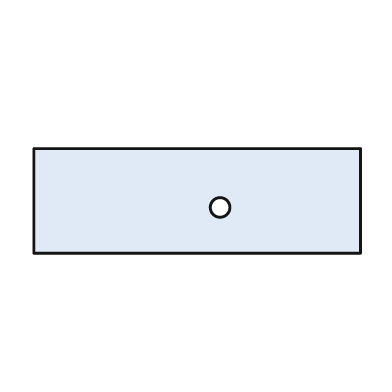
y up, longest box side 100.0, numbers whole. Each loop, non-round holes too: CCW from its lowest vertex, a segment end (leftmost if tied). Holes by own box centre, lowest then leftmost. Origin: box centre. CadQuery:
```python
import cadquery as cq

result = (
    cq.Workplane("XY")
    .moveTo(-50.0, -16.0)
    .lineTo(50.0, -16.0)
    .lineTo(50.0, 16.0)
    .lineTo(-50.0, 16.0)
    .close()
    .moveTo(7.0, -2.0)
    .circle(3.0)
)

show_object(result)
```